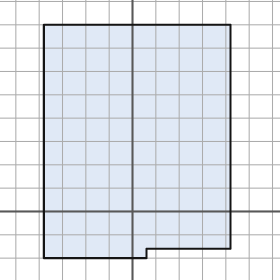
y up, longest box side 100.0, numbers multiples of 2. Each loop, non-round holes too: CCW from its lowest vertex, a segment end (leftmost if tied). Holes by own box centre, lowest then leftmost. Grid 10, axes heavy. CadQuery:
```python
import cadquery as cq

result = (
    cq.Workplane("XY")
    .moveTo(-38.0, -20.0)
    .lineTo(6.0, -20.0)
    .lineTo(6.0, -16.0)
    .lineTo(42.0, -16.0)
    .lineTo(42.0, 80.0)
    .lineTo(-38.0, 80.0)
    .close()
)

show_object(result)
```